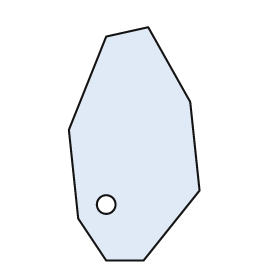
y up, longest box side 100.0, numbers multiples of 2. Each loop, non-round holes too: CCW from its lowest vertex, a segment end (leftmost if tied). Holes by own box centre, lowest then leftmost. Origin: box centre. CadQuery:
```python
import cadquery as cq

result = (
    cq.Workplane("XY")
    .moveTo(-12.0, -50.0)
    .lineTo(4.0, -50.0)
    .lineTo(28.0, -20.0)
    .lineTo(24.0, 18.0)
    .lineTo(6.0, 50.0)
    .lineTo(-12.0, 46.0)
    .lineTo(-28.0, 6.0)
    .lineTo(-24.0, -32.0)
    .close()
    .moveTo(-12.0, -26.0)
    .circle(4.0)
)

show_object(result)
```